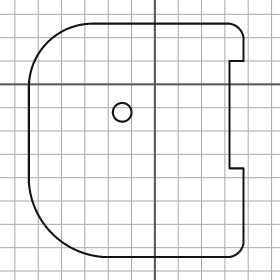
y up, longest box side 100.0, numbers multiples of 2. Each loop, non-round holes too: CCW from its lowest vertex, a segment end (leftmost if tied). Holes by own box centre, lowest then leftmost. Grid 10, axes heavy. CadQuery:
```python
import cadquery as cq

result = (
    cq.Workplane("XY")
    .moveTo(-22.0, -74.0)
    .lineTo(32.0, -74.0)
    .threePointArc((36.0, -72.0), (38.0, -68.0))
    .lineTo(38.0, -36.0)
    .lineTo(32.0, -36.0)
    .lineTo(32.0, 10.0)
    .lineTo(38.0, 10.0)
    .lineTo(38.0, 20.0)
    .threePointArc((36.0, 24.0), (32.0, 26.0))
    .lineTo(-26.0, 26.0)
    .threePointArc((-46.0, 18.0), (-54.0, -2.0))
    .lineTo(-54.0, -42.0)
    .threePointArc((-44.0, -64.0), (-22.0, -74.0))
    .close()
    .moveTo(-14.0, -12.0)
    .circle(4.0)
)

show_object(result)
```